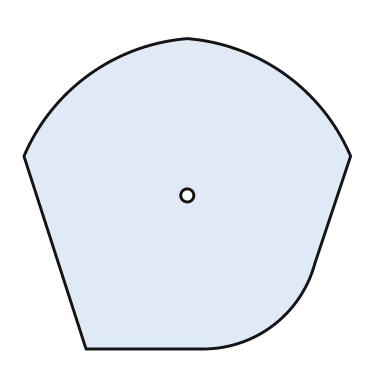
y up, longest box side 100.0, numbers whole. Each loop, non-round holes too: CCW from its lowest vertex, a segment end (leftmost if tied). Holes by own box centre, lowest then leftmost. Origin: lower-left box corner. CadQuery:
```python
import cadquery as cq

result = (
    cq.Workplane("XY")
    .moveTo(19.0, 0.0)
    .lineTo(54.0, 0.0)
    .threePointArc((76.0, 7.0), (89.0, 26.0))
    .lineTo(100.0, 59.0)
    .threePointArc((80.0, 84.0), (50.0, 95.0))
    .threePointArc((20.0, 84.0), (0.0, 59.0))
    .close()
    .moveTo(50.0, 47.0)
    .circle(2.0)
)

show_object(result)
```